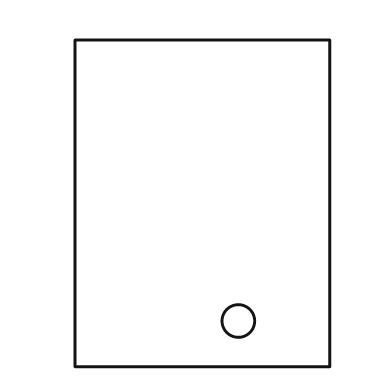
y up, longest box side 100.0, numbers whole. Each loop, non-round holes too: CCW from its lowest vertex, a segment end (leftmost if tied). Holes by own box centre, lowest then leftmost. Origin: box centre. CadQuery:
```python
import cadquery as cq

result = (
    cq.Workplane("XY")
    .moveTo(-39.0, -50.0)
    .lineTo(39.0, -50.0)
    .lineTo(39.0, 50.0)
    .lineTo(-39.0, 50.0)
    .close()
    .moveTo(11.0, -36.0)
    .circle(5.0)
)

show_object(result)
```